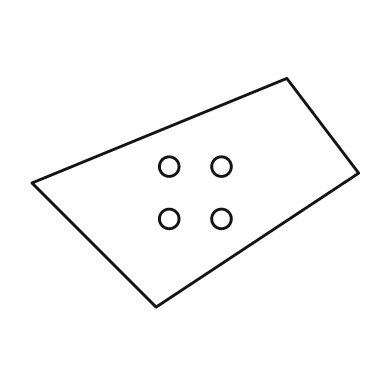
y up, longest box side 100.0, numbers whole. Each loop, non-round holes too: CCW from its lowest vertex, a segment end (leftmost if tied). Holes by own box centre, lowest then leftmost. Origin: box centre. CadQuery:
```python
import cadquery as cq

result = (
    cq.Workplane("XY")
    .moveTo(-12.0, -35.0)
    .lineTo(50.0, 6.0)
    .lineTo(28.0, 35.0)
    .lineTo(-50.0, 3.0)
    .close()
    .moveTo(-8.0, -8.0)
    .circle(3.0)
    .moveTo(8.0, -8.0)
    .circle(3.0)
    .moveTo(-8.0, 8.0)
    .circle(3.0)
    .moveTo(8.0, 8.0)
    .circle(3.0)
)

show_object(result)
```